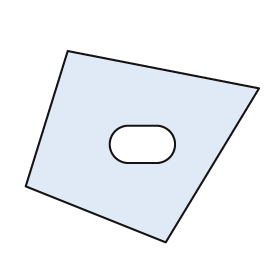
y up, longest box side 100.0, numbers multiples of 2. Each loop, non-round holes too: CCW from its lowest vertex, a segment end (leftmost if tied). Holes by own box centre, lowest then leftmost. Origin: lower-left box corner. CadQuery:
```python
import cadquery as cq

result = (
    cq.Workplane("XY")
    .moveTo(60.0, 0.0)
    .lineTo(100.0, 66.0)
    .lineTo(18.0, 82.0)
    .lineTo(0.0, 24.0)
    .close()
    .moveTo(44.0, 34.0)
    .lineTo(56.0, 34.0)
    .threePointArc((64.0, 42.0), (56.0, 50.0))
    .lineTo(44.0, 50.0)
    .threePointArc((36.0, 42.0), (44.0, 34.0))
    .close()
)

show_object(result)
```